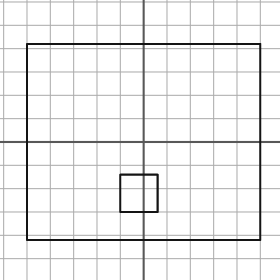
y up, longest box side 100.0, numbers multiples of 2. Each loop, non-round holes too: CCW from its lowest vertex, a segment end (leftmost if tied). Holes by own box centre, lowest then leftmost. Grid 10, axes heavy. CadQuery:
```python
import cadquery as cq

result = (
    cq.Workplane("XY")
    .moveTo(-50.0, -42.0)
    .lineTo(50.0, -42.0)
    .lineTo(50.0, 42.0)
    .lineTo(-50.0, 42.0)
    .close()
    .moveTo(-10.0, -30.0)
    .lineTo(6.0, -30.0)
    .lineTo(6.0, -14.0)
    .lineTo(-10.0, -14.0)
    .close()
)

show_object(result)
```